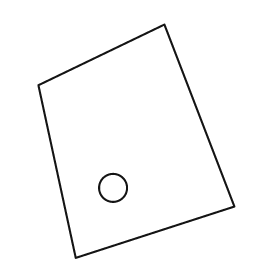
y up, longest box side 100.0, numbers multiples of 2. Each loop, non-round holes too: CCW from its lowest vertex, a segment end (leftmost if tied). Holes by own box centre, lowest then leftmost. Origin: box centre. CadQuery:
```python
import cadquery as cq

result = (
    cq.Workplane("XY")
    .moveTo(-26.0, -50.0)
    .lineTo(42.0, -28.0)
    .lineTo(12.0, 50.0)
    .lineTo(-42.0, 24.0)
    .close()
    .moveTo(-10.0, -20.0)
    .circle(6.0)
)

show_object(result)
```